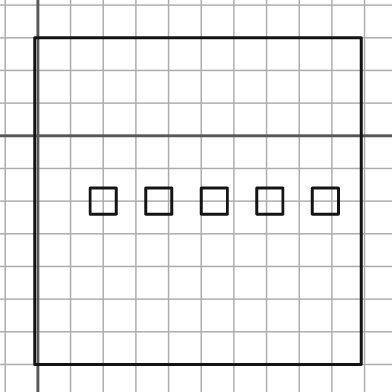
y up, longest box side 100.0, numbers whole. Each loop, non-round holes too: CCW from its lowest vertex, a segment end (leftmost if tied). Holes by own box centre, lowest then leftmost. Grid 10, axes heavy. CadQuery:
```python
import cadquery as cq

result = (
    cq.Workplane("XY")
    .moveTo(-1.0, -70.0)
    .lineTo(99.0, -70.0)
    .lineTo(99.0, 30.0)
    .lineTo(-1.0, 30.0)
    .close()
    .moveTo(16.0, -24.0)
    .lineTo(24.0, -24.0)
    .lineTo(24.0, -16.0)
    .lineTo(16.0, -16.0)
    .close()
    .moveTo(33.0, -24.0)
    .lineTo(41.0, -24.0)
    .lineTo(41.0, -16.0)
    .lineTo(33.0, -16.0)
    .close()
    .moveTo(50.0, -24.0)
    .lineTo(58.0, -24.0)
    .lineTo(58.0, -16.0)
    .lineTo(50.0, -16.0)
    .close()
    .moveTo(67.0, -24.0)
    .lineTo(75.0, -24.0)
    .lineTo(75.0, -16.0)
    .lineTo(67.0, -16.0)
    .close()
    .moveTo(84.0, -24.0)
    .lineTo(92.0, -24.0)
    .lineTo(92.0, -16.0)
    .lineTo(84.0, -16.0)
    .close()
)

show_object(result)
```